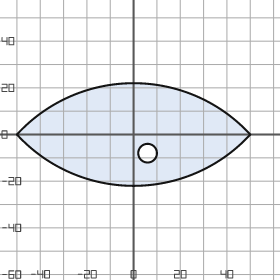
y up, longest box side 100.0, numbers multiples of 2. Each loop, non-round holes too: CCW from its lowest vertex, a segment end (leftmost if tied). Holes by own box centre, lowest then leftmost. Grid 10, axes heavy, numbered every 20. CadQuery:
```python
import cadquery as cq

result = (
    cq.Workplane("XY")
    .moveTo(-50.0, 0.0)
    .threePointArc((0.0, -22.0), (50.0, 0.0))
    .threePointArc((0.0, 22.0), (-50.0, 0.0))
    .close()
    .moveTo(6.0, -8.0)
    .circle(4.0)
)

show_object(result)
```